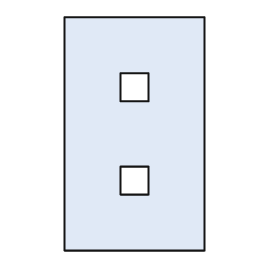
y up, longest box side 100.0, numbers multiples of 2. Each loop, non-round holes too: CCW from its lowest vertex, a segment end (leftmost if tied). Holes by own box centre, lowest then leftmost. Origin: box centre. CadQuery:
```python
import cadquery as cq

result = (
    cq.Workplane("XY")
    .moveTo(-30.0, -50.0)
    .lineTo(30.0, -50.0)
    .lineTo(30.0, 50.0)
    .lineTo(-30.0, 50.0)
    .close()
    .moveTo(-6.0, -26.0)
    .lineTo(6.0, -26.0)
    .lineTo(6.0, -14.0)
    .lineTo(-6.0, -14.0)
    .close()
    .moveTo(-6.0, 14.0)
    .lineTo(6.0, 14.0)
    .lineTo(6.0, 26.0)
    .lineTo(-6.0, 26.0)
    .close()
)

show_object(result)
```